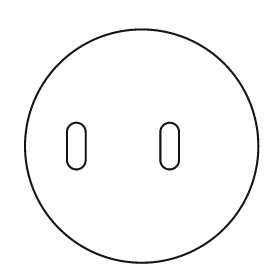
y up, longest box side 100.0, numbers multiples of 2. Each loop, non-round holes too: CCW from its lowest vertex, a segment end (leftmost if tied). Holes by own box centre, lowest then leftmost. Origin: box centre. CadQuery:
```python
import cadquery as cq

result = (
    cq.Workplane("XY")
    .moveTo(0.0, 0.0)
    .circle(50.0)
    .moveTo(-32.0, -6.0)
    .threePointArc((-28.0, -10.0), (-24.0, -6.0))
    .lineTo(-24.0, 6.0)
    .threePointArc((-28.0, 10.0), (-32.0, 6.0))
    .close()
    .moveTo(8.0, -6.0)
    .threePointArc((12.0, -10.0), (16.0, -6.0))
    .lineTo(16.0, 6.0)
    .threePointArc((12.0, 10.0), (8.0, 6.0))
    .close()
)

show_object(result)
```